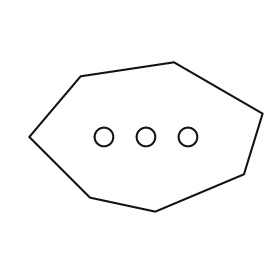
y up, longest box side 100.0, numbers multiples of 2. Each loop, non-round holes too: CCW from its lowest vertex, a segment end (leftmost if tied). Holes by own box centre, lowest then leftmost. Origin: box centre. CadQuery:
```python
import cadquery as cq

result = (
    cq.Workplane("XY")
    .moveTo(4.0, -32.0)
    .lineTo(42.0, -16.0)
    .lineTo(50.0, 10.0)
    .lineTo(12.0, 32.0)
    .lineTo(-28.0, 26.0)
    .lineTo(-50.0, 0.0)
    .lineTo(-24.0, -26.0)
    .close()
    .moveTo(-18.0, 0.0)
    .circle(4.0)
    .moveTo(0.0, 0.0)
    .circle(4.0)
    .moveTo(18.0, 0.0)
    .circle(4.0)
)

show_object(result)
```